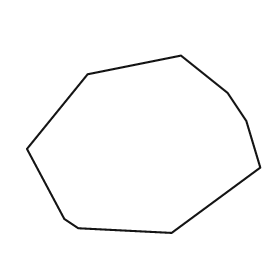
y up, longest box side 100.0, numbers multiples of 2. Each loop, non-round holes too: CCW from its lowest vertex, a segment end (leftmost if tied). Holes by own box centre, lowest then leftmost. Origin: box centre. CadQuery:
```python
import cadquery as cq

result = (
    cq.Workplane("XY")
    .moveTo(12.0, -38.0)
    .lineTo(50.0, -10.0)
    .lineTo(44.0, 10.0)
    .lineTo(36.0, 22.0)
    .lineTo(16.0, 38.0)
    .lineTo(-24.0, 30.0)
    .lineTo(-50.0, -2.0)
    .lineTo(-34.0, -32.0)
    .lineTo(-28.0, -36.0)
    .close()
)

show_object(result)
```